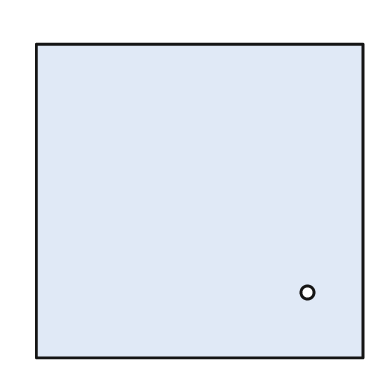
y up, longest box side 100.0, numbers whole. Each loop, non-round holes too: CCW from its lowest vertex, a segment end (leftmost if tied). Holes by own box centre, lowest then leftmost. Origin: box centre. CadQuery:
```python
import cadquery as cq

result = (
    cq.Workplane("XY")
    .moveTo(-50.0, -48.0)
    .lineTo(50.0, -48.0)
    .lineTo(50.0, 48.0)
    .lineTo(-50.0, 48.0)
    .close()
    .moveTo(33.0, -28.0)
    .circle(2.0)
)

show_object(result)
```